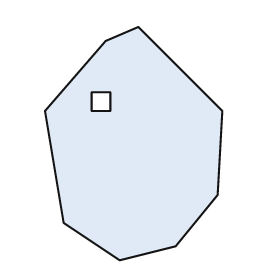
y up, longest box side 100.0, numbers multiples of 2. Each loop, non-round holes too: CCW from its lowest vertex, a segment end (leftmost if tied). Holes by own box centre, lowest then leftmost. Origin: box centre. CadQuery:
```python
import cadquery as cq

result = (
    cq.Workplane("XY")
    .moveTo(-6.0, -50.0)
    .lineTo(18.0, -44.0)
    .lineTo(36.0, -22.0)
    .lineTo(38.0, 14.0)
    .lineTo(2.0, 50.0)
    .lineTo(-12.0, 44.0)
    .lineTo(-38.0, 14.0)
    .lineTo(-30.0, -34.0)
    .close()
    .moveTo(-18.0, 14.0)
    .lineTo(-10.0, 14.0)
    .lineTo(-10.0, 22.0)
    .lineTo(-18.0, 22.0)
    .close()
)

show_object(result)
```